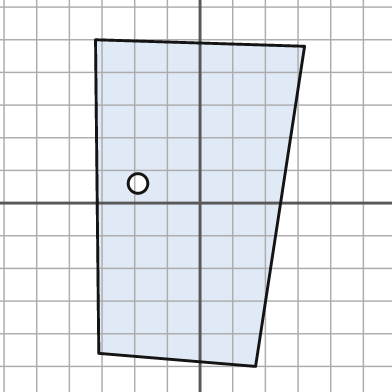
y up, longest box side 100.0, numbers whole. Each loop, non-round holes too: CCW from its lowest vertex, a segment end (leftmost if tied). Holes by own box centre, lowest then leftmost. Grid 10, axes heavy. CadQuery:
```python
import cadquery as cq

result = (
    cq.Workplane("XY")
    .moveTo(17.0, -50.0)
    .lineTo(32.0, 48.0)
    .lineTo(-32.0, 50.0)
    .lineTo(-31.0, -46.0)
    .close()
    .moveTo(-19.0, 6.0)
    .circle(3.0)
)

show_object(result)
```